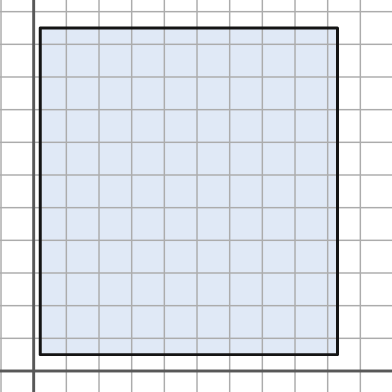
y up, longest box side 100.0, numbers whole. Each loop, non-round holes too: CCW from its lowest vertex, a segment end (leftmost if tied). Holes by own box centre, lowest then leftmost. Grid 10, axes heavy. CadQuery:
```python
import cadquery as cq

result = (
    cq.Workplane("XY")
    .moveTo(2.0, 5.0)
    .lineTo(93.0, 5.0)
    .lineTo(93.0, 105.0)
    .lineTo(2.0, 105.0)
    .close()
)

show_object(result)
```